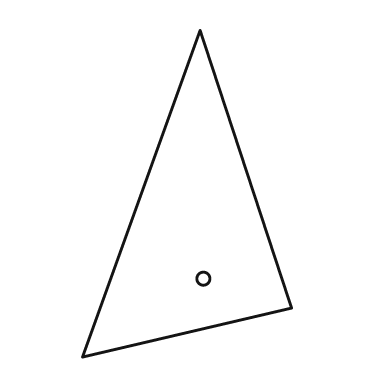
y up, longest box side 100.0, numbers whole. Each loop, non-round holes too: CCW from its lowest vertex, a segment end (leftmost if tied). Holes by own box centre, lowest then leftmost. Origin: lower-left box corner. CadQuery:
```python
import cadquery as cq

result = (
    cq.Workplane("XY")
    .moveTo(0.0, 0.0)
    .lineTo(64.0, 15.0)
    .lineTo(36.0, 100.0)
    .close()
    .moveTo(37.0, 24.0)
    .circle(2.0)
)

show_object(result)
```